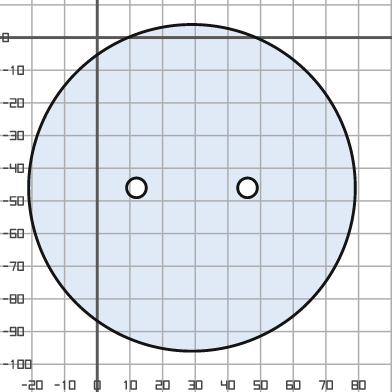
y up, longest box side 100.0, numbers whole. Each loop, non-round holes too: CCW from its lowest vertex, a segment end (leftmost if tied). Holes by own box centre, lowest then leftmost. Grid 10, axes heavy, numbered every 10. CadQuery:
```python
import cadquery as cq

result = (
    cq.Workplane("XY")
    .moveTo(29.0, -46.0)
    .circle(50.0)
    .moveTo(12.0, -46.0)
    .circle(3.0)
    .moveTo(46.0, -46.0)
    .circle(3.0)
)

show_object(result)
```